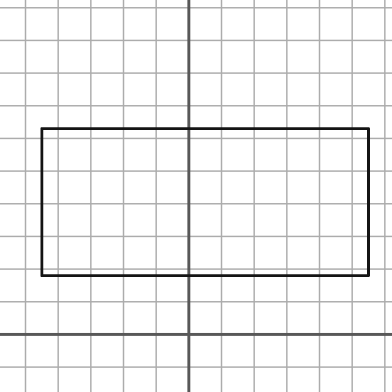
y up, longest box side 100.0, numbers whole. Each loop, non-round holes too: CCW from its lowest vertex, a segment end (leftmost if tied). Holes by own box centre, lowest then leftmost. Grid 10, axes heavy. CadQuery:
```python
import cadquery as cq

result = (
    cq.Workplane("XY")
    .moveTo(-45.0, 18.0)
    .lineTo(55.0, 18.0)
    .lineTo(55.0, 63.0)
    .lineTo(-45.0, 63.0)
    .close()
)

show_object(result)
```